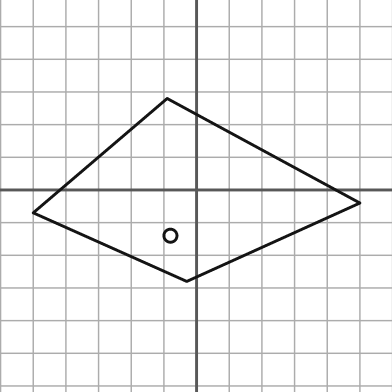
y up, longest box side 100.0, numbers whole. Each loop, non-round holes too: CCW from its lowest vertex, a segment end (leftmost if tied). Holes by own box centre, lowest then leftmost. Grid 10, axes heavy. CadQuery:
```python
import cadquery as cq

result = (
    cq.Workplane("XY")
    .moveTo(-3.0, -28.0)
    .lineTo(50.0, -4.0)
    .lineTo(-9.0, 28.0)
    .lineTo(-50.0, -7.0)
    .close()
    .moveTo(-8.0, -14.0)
    .circle(2.0)
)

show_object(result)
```